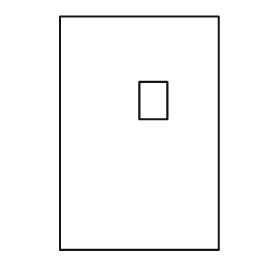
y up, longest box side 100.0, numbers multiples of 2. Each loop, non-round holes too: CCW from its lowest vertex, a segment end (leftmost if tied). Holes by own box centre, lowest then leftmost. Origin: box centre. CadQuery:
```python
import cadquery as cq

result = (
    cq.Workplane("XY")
    .moveTo(-34.0, -50.0)
    .lineTo(34.0, -50.0)
    .lineTo(34.0, 50.0)
    .lineTo(-34.0, 50.0)
    .close()
    .moveTo(0.0, 6.0)
    .lineTo(12.0, 6.0)
    .lineTo(12.0, 22.0)
    .lineTo(0.0, 22.0)
    .close()
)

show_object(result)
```